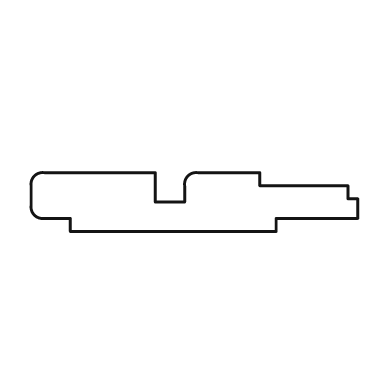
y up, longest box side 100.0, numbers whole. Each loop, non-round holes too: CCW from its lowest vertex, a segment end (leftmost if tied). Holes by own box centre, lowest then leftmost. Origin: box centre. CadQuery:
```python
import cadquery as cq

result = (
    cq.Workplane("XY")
    .moveTo(-38.0, -9.0)
    .lineTo(25.0, -9.0)
    .lineTo(25.0, -5.0)
    .lineTo(50.0, -5.0)
    .lineTo(50.0, 1.0)
    .lineTo(47.0, 1.0)
    .lineTo(47.0, 5.0)
    .lineTo(20.0, 5.0)
    .lineTo(20.0, 9.0)
    .lineTo(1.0, 9.0)
    .threePointArc((-2.0, 8.0), (-3.0, 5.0))
    .lineTo(-3.0, 0.0)
    .lineTo(-12.0, 0.0)
    .lineTo(-12.0, 9.0)
    .lineTo(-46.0, 9.0)
    .threePointArc((-49.0, 8.0), (-50.0, 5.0))
    .lineTo(-50.0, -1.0)
    .threePointArc((-49.0, -4.0), (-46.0, -5.0))
    .lineTo(-38.0, -5.0)
    .close()
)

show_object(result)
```